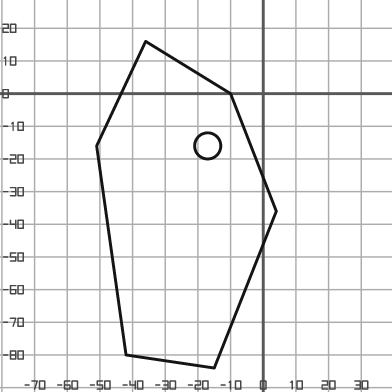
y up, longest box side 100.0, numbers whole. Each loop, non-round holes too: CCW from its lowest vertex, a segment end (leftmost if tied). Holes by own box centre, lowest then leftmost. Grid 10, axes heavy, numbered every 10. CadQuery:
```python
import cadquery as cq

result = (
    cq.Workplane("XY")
    .moveTo(-15.0, -84.0)
    .lineTo(4.0, -36.0)
    .lineTo(-10.0, 0.0)
    .lineTo(-36.0, 16.0)
    .lineTo(-51.0, -16.0)
    .lineTo(-42.0, -80.0)
    .close()
    .moveTo(-17.0, -16.0)
    .circle(4.0)
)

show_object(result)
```